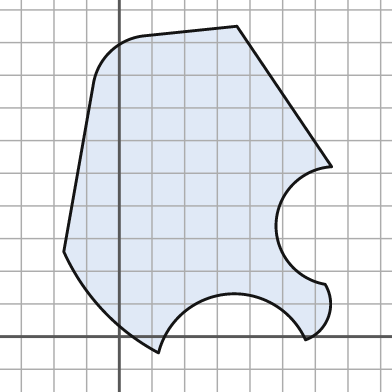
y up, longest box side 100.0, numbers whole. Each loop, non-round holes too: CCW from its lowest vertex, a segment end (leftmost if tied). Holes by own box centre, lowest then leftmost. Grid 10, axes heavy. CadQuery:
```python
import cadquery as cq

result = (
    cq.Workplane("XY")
    .moveTo(12.0, -5.0)
    .threePointArc((33.0, 13.0), (57.0, -1.0))
    .threePointArc((64.0, 6.0), (63.0, 16.0))
    .threePointArc((48.0, 35.0), (65.0, 52.0))
    .lineTo(36.0, 95.0)
    .lineTo(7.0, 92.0)
    .threePointArc((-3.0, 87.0), (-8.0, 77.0))
    .lineTo(-17.0, 26.0)
    .threePointArc((-5.0, 8.0), (12.0, -5.0))
    .close()
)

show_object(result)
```